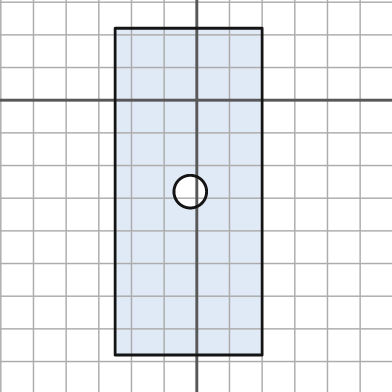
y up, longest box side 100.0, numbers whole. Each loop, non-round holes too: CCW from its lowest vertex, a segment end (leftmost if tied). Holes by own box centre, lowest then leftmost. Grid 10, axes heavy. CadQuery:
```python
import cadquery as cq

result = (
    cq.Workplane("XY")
    .moveTo(-25.0, -78.0)
    .lineTo(20.0, -78.0)
    .lineTo(20.0, 22.0)
    .lineTo(-25.0, 22.0)
    .close()
    .moveTo(-2.0, -28.0)
    .circle(5.0)
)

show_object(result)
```